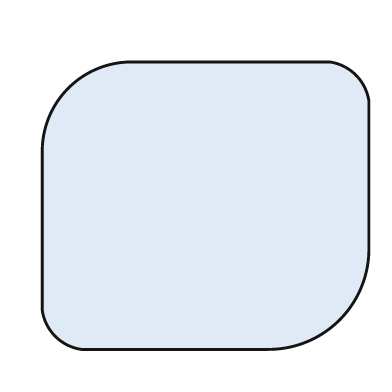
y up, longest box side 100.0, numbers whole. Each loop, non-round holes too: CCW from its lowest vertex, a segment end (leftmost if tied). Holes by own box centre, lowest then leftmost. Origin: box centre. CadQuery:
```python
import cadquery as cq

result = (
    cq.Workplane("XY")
    .moveTo(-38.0, -44.0)
    .lineTo(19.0, -44.0)
    .threePointArc((41.0, -35.0), (50.0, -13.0))
    .lineTo(50.0, 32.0)
    .threePointArc((46.0, 40.0), (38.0, 44.0))
    .lineTo(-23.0, 44.0)
    .threePointArc((-42.0, 36.0), (-50.0, 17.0))
    .lineTo(-50.0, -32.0)
    .threePointArc((-46.0, -40.0), (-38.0, -44.0))
    .close()
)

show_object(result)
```